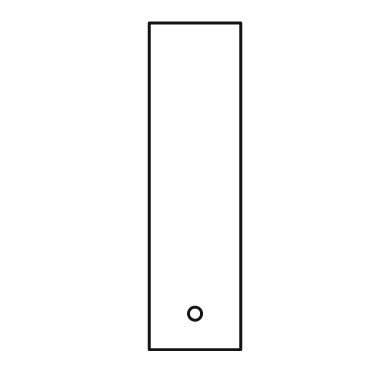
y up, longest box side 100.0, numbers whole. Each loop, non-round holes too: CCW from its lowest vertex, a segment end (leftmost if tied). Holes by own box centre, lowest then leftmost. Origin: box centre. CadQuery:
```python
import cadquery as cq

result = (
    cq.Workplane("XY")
    .moveTo(-14.0, -50.0)
    .lineTo(14.0, -50.0)
    .lineTo(14.0, 50.0)
    .lineTo(-14.0, 50.0)
    .close()
    .moveTo(0.0, -39.0)
    .circle(2.0)
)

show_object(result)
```